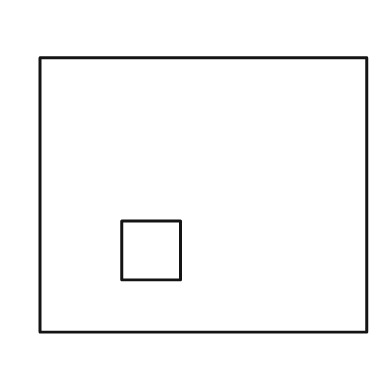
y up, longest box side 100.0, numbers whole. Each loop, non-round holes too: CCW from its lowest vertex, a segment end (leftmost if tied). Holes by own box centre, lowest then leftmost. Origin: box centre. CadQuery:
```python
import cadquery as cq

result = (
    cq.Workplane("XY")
    .moveTo(-50.0, -42.0)
    .lineTo(50.0, -42.0)
    .lineTo(50.0, 42.0)
    .lineTo(-50.0, 42.0)
    .close()
    .moveTo(-25.0, -26.0)
    .lineTo(-7.0, -26.0)
    .lineTo(-7.0, -8.0)
    .lineTo(-25.0, -8.0)
    .close()
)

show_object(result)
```